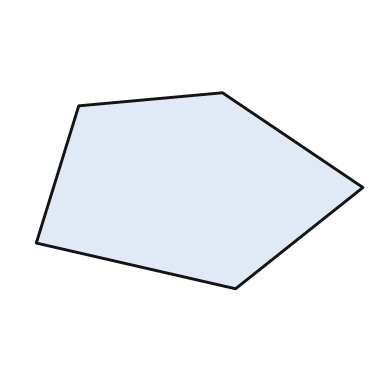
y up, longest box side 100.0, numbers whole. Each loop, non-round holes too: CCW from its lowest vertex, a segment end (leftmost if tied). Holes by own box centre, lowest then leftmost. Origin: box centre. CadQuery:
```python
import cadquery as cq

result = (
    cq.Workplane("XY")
    .moveTo(11.0, -30.0)
    .lineTo(50.0, 1.0)
    .lineTo(7.0, 30.0)
    .lineTo(-37.0, 26.0)
    .lineTo(-50.0, -16.0)
    .close()
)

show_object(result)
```